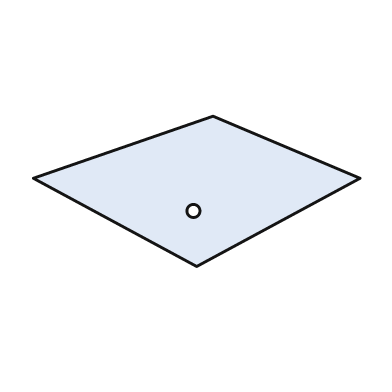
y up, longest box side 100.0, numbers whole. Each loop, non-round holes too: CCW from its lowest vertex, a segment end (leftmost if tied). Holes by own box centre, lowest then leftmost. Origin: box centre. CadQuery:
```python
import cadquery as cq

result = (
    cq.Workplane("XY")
    .moveTo(0.0, -23.0)
    .lineTo(50.0, 4.0)
    .lineTo(5.0, 23.0)
    .lineTo(-50.0, 4.0)
    .close()
    .moveTo(-1.0, -6.0)
    .circle(2.0)
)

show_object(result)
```